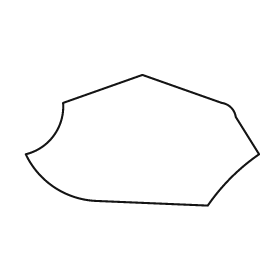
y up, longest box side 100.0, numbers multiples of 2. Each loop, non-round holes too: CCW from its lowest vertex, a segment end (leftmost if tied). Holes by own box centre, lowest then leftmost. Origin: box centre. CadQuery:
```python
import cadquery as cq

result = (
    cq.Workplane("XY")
    .moveTo(28.0, -28.0)
    .threePointArc((38.0, -16.0), (50.0, -6.0))
    .lineTo(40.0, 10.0)
    .threePointArc((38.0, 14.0), (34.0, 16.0))
    .lineTo(0.0, 28.0)
    .lineTo(-34.0, 16.0)
    .threePointArc((-38.0, 2.0), (-50.0, -6.0))
    .threePointArc((-38.0, -20.0), (-20.0, -26.0))
    .close()
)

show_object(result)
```